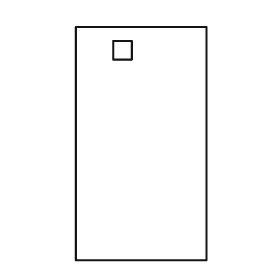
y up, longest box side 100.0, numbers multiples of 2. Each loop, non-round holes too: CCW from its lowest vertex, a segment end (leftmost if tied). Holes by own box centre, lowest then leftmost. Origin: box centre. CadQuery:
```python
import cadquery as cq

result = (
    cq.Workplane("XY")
    .moveTo(-28.0, -50.0)
    .lineTo(28.0, -50.0)
    .lineTo(28.0, 50.0)
    .lineTo(-28.0, 50.0)
    .close()
    .moveTo(-12.0, 36.0)
    .lineTo(-4.0, 36.0)
    .lineTo(-4.0, 44.0)
    .lineTo(-12.0, 44.0)
    .close()
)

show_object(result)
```